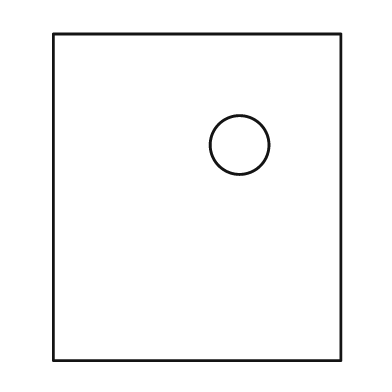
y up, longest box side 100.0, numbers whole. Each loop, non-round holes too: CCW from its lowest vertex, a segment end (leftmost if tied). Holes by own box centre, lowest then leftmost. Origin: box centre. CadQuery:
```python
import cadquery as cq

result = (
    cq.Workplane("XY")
    .moveTo(-44.0, -50.0)
    .lineTo(44.0, -50.0)
    .lineTo(44.0, 50.0)
    .lineTo(-44.0, 50.0)
    .close()
    .moveTo(13.0, 16.0)
    .circle(9.0)
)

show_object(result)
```